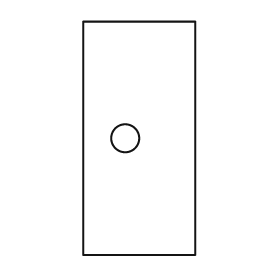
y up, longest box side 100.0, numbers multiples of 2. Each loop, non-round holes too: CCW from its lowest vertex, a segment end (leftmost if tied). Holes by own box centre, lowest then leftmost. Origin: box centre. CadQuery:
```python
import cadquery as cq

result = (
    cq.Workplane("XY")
    .moveTo(-24.0, -50.0)
    .lineTo(24.0, -50.0)
    .lineTo(24.0, 50.0)
    .lineTo(-24.0, 50.0)
    .close()
    .moveTo(-6.0, 0.0)
    .circle(6.0)
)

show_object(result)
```